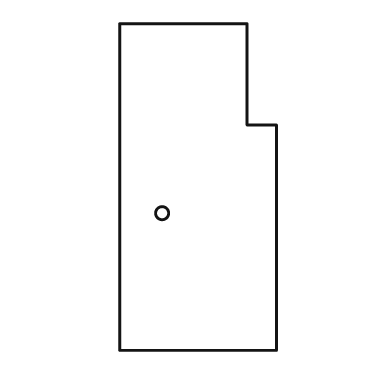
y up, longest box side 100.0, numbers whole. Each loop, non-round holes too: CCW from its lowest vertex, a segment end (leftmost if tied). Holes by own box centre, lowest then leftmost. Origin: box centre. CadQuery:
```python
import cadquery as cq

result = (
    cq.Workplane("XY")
    .moveTo(-24.0, -50.0)
    .lineTo(24.0, -50.0)
    .lineTo(24.0, 19.0)
    .lineTo(15.0, 19.0)
    .lineTo(15.0, 50.0)
    .lineTo(-24.0, 50.0)
    .close()
    .moveTo(-11.0, -8.0)
    .circle(2.0)
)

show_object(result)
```